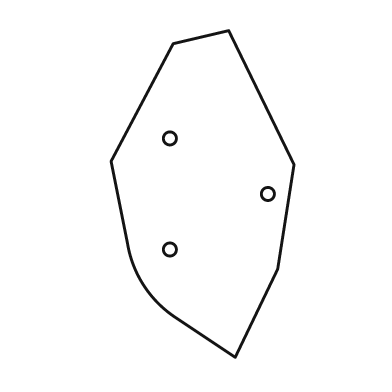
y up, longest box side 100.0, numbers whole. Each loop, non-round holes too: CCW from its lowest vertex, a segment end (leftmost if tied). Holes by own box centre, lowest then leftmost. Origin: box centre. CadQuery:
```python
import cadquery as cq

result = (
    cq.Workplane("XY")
    .moveTo(10.0, -50.0)
    .lineTo(23.0, -23.0)
    .lineTo(28.0, 9.0)
    .lineTo(8.0, 50.0)
    .lineTo(-9.0, 46.0)
    .lineTo(-28.0, 10.0)
    .lineTo(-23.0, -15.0)
    .threePointArc((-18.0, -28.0), (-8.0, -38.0))
    .close()
    .moveTo(-10.0, -17.0)
    .circle(2.0)
    .moveTo(20.0, 0.0)
    .circle(2.0)
    .moveTo(-10.0, 17.0)
    .circle(2.0)
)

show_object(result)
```